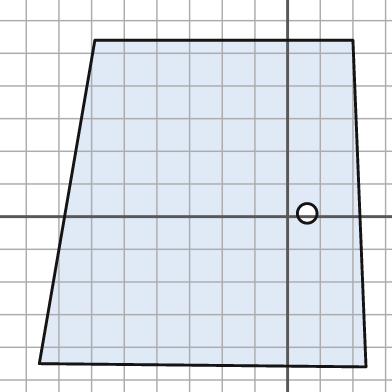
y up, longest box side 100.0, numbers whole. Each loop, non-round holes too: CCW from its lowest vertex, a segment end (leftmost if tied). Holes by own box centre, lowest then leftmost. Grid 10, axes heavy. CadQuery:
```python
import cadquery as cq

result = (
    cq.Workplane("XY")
    .moveTo(24.0, -46.0)
    .lineTo(20.0, 54.0)
    .lineTo(-59.0, 54.0)
    .lineTo(-76.0, -45.0)
    .close()
    .moveTo(6.0, 1.0)
    .circle(3.0)
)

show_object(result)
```